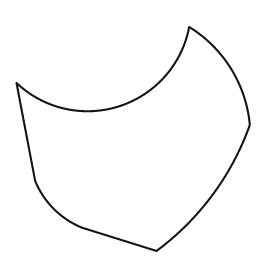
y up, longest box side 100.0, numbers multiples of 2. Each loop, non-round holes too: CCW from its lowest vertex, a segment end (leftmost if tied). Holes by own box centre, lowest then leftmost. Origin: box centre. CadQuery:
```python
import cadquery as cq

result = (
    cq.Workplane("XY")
    .moveTo(10.0, -48.0)
    .threePointArc((34.0, -24.0), (50.0, 6.0))
    .threePointArc((42.0, 30.0), (24.0, 48.0))
    .threePointArc((-6.0, 14.0), (-50.0, 24.0))
    .lineTo(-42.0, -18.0)
    .threePointArc((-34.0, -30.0), (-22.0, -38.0))
    .close()
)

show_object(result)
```